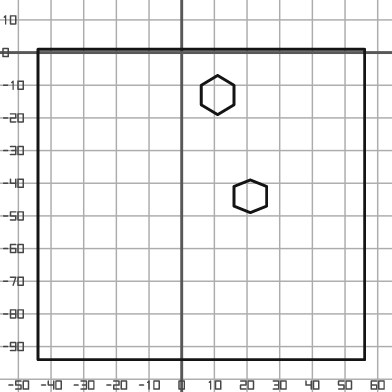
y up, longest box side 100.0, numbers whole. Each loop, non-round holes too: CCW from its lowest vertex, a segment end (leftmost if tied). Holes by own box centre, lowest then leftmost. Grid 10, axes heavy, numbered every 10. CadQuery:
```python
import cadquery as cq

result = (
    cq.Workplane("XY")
    .moveTo(-44.0, -94.0)
    .lineTo(56.0, -94.0)
    .lineTo(56.0, 1.0)
    .lineTo(-44.0, 1.0)
    .close()
    .moveTo(21.0, -49.0)
    .lineTo(26.0, -47.0)
    .lineTo(26.0, -41.0)
    .lineTo(21.0, -39.0)
    .lineTo(16.0, -41.0)
    .lineTo(16.0, -47.0)
    .close()
    .moveTo(11.0, -19.0)
    .lineTo(16.0, -16.0)
    .lineTo(16.0, -10.0)
    .lineTo(11.0, -7.0)
    .lineTo(6.0, -10.0)
    .lineTo(6.0, -16.0)
    .close()
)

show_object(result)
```